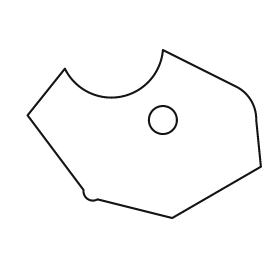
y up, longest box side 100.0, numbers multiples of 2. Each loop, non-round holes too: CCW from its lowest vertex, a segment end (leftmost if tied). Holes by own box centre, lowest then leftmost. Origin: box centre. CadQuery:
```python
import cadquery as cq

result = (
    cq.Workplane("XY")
    .moveTo(12.0, -36.0)
    .lineTo(50.0, -14.0)
    .lineTo(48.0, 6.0)
    .threePointArc((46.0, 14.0), (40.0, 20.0))
    .lineTo(8.0, 36.0)
    .threePointArc((-10.0, 16.0), (-34.0, 28.0))
    .lineTo(-50.0, 8.0)
    .lineTo(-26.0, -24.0)
    .threePointArc((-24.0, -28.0), (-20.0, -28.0))
    .close()
    .moveTo(8.0, 6.0)
    .circle(6.0)
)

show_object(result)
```